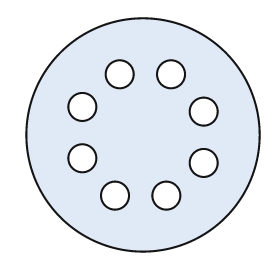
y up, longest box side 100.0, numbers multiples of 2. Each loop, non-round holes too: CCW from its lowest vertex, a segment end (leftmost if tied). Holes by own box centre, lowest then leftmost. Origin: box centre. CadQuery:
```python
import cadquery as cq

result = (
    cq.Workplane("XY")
    .moveTo(0.0, 0.0)
    .circle(50.0)
    .moveTo(-12.0, -26.0)
    .circle(6.0)
    .moveTo(10.0, -26.0)
    .circle(6.0)
    .moveTo(26.0, -12.0)
    .circle(6.0)
    .moveTo(-26.0, -10.0)
    .circle(6.0)
    .moveTo(26.0, 10.0)
    .circle(6.0)
    .moveTo(-26.0, 12.0)
    .circle(6.0)
    .moveTo(-10.0, 26.0)
    .circle(6.0)
    .moveTo(12.0, 26.0)
    .circle(6.0)
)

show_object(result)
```